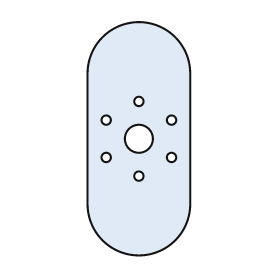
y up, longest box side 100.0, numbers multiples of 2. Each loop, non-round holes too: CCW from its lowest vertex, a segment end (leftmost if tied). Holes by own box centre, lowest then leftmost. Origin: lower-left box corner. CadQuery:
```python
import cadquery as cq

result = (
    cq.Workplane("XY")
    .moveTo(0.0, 22.0)
    .threePointArc((22.0, 0.0), (44.0, 22.0))
    .lineTo(44.0, 78.0)
    .threePointArc((22.0, 100.0), (0.0, 78.0))
    .close()
    .moveTo(22.0, 34.0)
    .circle(2.0)
    .moveTo(8.0, 42.0)
    .circle(2.0)
    .moveTo(36.0, 42.0)
    .circle(2.0)
    .moveTo(22.0, 50.0)
    .circle(6.0)
    .moveTo(8.0, 58.0)
    .circle(2.0)
    .moveTo(36.0, 58.0)
    .circle(2.0)
    .moveTo(22.0, 66.0)
    .circle(2.0)
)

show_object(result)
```